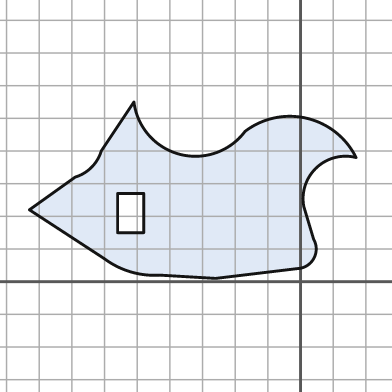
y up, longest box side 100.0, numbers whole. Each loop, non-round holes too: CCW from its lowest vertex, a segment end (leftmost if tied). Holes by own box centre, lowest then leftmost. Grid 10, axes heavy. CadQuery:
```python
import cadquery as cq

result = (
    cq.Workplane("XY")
    .moveTo(-26.0, 1.0)
    .lineTo(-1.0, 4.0)
    .threePointArc((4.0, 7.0), (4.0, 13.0))
    .lineTo(1.0, 23.0)
    .threePointArc((5.0, 35.0), (17.0, 38.0))
    .threePointArc((2.0, 50.0), (-17.0, 46.0))
    .threePointArc((-37.0, 39.0), (-51.0, 55.0))
    .lineTo(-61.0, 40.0)
    .threePointArc((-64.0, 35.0), (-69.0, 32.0))
    .lineTo(-83.0, 22.0)
    .lineTo(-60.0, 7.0)
    .threePointArc((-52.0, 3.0), (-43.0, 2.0))
    .close()
    .moveTo(-56.0, 15.0)
    .lineTo(-48.0, 15.0)
    .lineTo(-48.0, 27.0)
    .lineTo(-56.0, 27.0)
    .close()
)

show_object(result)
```